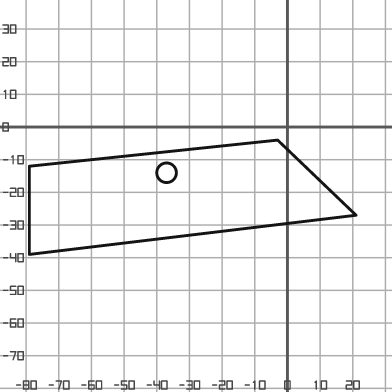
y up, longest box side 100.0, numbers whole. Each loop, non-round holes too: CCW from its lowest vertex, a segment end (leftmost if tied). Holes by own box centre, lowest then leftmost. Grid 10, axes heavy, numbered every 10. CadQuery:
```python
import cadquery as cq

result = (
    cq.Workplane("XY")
    .moveTo(-79.0, -39.0)
    .lineTo(21.0, -27.0)
    .lineTo(-3.0, -4.0)
    .lineTo(-79.0, -12.0)
    .close()
    .moveTo(-37.0, -14.0)
    .circle(3.0)
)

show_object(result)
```